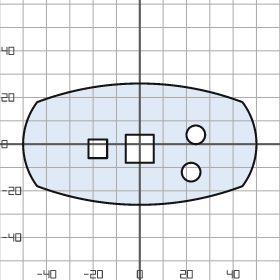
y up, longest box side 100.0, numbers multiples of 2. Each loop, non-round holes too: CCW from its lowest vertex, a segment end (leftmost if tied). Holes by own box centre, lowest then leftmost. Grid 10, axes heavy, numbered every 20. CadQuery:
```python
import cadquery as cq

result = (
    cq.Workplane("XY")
    .moveTo(-44.0, -18.0)
    .threePointArc((0.0, -26.0), (44.0, -18.0))
    .threePointArc((50.0, 0.0), (44.0, 18.0))
    .threePointArc((0.0, 26.0), (-44.0, 18.0))
    .threePointArc((-50.0, 0.0), (-44.0, -18.0))
    .close()
    .moveTo(22.0, -12.0)
    .circle(4.0)
    .moveTo(-22.0, -6.0)
    .lineTo(-14.0, -6.0)
    .lineTo(-14.0, 2.0)
    .lineTo(-22.0, 2.0)
    .close()
    .moveTo(-6.0, -8.0)
    .lineTo(6.0, -8.0)
    .lineTo(6.0, 4.0)
    .lineTo(-6.0, 4.0)
    .close()
    .moveTo(24.0, 4.0)
    .circle(4.0)
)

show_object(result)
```